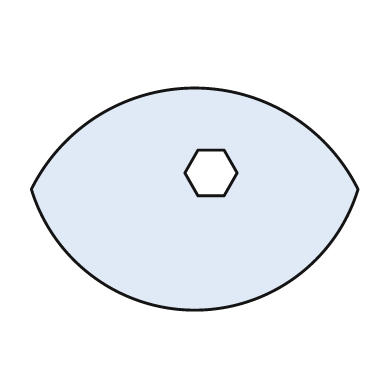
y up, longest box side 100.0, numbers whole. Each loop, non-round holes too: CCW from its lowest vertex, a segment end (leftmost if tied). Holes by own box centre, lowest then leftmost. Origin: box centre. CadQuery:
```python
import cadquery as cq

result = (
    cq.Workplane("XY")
    .moveTo(-50.0, 3.0)
    .threePointArc((0.0, -34.0), (50.0, 3.0))
    .threePointArc((0.0, 34.0), (-50.0, 3.0))
    .close()
    .moveTo(1.0, 1.0)
    .lineTo(9.0, 1.0)
    .lineTo(13.0, 8.0)
    .lineTo(9.0, 15.0)
    .lineTo(1.0, 15.0)
    .lineTo(-3.0, 8.0)
    .close()
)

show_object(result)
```